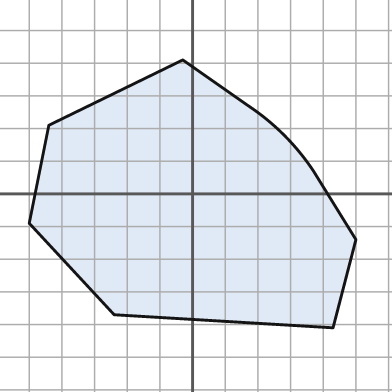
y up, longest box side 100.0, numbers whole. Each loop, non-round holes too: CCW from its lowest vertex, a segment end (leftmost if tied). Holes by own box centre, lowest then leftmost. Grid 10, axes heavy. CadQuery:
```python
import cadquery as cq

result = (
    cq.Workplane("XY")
    .moveTo(43.0, -41.0)
    .lineTo(50.0, -14.0)
    .lineTo(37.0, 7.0)
    .threePointArc((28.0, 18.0), (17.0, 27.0))
    .lineTo(-3.0, 41.0)
    .lineTo(-44.0, 21.0)
    .lineTo(-50.0, -9.0)
    .lineTo(-24.0, -37.0)
    .close()
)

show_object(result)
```